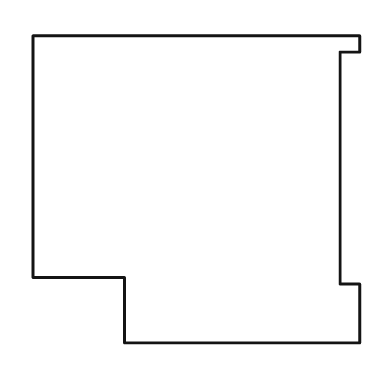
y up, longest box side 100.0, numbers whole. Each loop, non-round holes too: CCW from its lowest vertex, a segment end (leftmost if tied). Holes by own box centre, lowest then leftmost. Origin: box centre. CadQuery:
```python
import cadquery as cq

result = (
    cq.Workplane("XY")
    .moveTo(-22.0, -47.0)
    .lineTo(50.0, -47.0)
    .lineTo(50.0, -29.0)
    .lineTo(44.0, -29.0)
    .lineTo(44.0, 42.0)
    .lineTo(50.0, 42.0)
    .lineTo(50.0, 47.0)
    .lineTo(-50.0, 47.0)
    .lineTo(-50.0, -27.0)
    .lineTo(-22.0, -27.0)
    .close()
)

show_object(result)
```